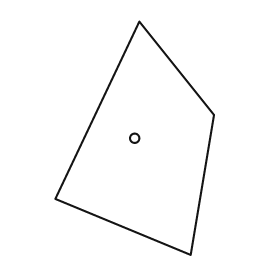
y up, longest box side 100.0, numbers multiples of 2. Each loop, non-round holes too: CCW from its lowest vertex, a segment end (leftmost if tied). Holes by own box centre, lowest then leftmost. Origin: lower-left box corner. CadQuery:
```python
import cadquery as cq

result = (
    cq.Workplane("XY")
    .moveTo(58.0, 0.0)
    .lineTo(68.0, 60.0)
    .lineTo(36.0, 100.0)
    .lineTo(0.0, 24.0)
    .close()
    .moveTo(34.0, 50.0)
    .circle(2.0)
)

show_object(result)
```